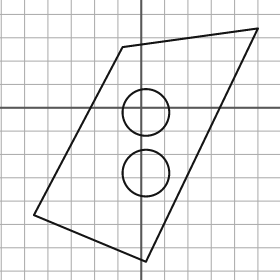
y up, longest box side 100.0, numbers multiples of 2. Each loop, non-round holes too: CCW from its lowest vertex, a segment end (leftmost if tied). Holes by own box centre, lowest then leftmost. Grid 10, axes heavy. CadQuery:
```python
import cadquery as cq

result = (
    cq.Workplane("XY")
    .moveTo(2.0, -66.0)
    .lineTo(50.0, 34.0)
    .lineTo(-8.0, 26.0)
    .lineTo(-46.0, -46.0)
    .close()
    .moveTo(2.0, -28.0)
    .circle(10.0)
    .moveTo(2.0, -2.0)
    .circle(10.0)
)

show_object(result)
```